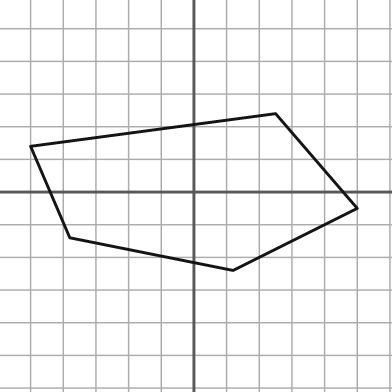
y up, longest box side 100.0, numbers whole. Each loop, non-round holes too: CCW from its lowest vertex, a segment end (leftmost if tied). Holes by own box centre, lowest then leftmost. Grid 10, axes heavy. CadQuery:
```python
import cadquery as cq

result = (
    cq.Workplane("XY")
    .moveTo(12.0, -24.0)
    .lineTo(50.0, -5.0)
    .lineTo(25.0, 24.0)
    .lineTo(-50.0, 14.0)
    .lineTo(-38.0, -14.0)
    .close()
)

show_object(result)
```